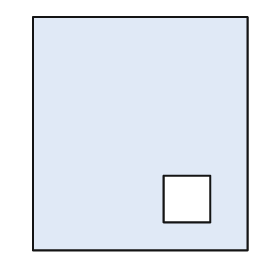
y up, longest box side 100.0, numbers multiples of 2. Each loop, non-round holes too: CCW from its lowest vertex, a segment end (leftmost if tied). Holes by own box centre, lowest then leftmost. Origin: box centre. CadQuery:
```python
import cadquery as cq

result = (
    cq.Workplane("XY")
    .moveTo(-46.0, -50.0)
    .lineTo(46.0, -50.0)
    .lineTo(46.0, 50.0)
    .lineTo(-46.0, 50.0)
    .close()
    .moveTo(10.0, -38.0)
    .lineTo(30.0, -38.0)
    .lineTo(30.0, -18.0)
    .lineTo(10.0, -18.0)
    .close()
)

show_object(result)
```